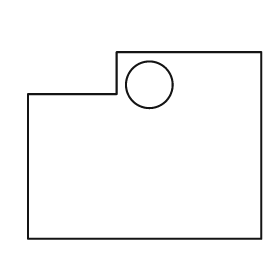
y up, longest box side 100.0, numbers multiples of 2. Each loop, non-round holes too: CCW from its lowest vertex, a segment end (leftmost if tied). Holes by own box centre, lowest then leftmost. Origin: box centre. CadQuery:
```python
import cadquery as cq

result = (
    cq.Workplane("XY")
    .moveTo(-50.0, -40.0)
    .lineTo(50.0, -40.0)
    .lineTo(50.0, 40.0)
    .lineTo(-12.0, 40.0)
    .lineTo(-12.0, 22.0)
    .lineTo(-50.0, 22.0)
    .close()
    .moveTo(2.0, 26.0)
    .circle(10.0)
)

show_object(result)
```